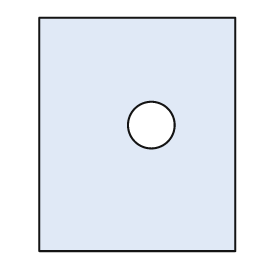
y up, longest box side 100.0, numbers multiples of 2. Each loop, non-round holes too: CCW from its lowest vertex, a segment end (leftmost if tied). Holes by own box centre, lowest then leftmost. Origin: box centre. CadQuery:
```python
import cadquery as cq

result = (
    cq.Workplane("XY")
    .moveTo(-42.0, -50.0)
    .lineTo(42.0, -50.0)
    .lineTo(42.0, 50.0)
    .lineTo(-42.0, 50.0)
    .close()
    .moveTo(6.0, 4.0)
    .circle(10.0)
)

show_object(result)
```